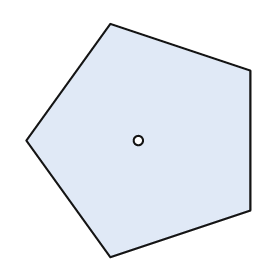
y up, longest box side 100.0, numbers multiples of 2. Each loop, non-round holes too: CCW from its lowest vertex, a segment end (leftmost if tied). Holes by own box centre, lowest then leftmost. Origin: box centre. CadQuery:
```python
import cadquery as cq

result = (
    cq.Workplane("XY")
    .moveTo(-12.0, -50.0)
    .lineTo(48.0, -30.0)
    .lineTo(48.0, 30.0)
    .lineTo(-12.0, 50.0)
    .lineTo(-48.0, 0.0)
    .close()
    .moveTo(0.0, 0.0)
    .circle(2.0)
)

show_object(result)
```